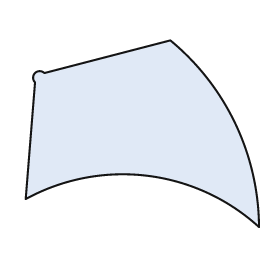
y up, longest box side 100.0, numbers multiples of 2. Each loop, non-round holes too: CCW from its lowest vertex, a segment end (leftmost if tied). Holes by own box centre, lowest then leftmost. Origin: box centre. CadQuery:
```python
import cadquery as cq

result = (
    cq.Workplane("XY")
    .moveTo(50.0, -40.0)
    .threePointArc((40.0, 4.0), (12.0, 40.0))
    .lineTo(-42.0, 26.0)
    .threePointArc((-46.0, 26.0), (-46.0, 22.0))
    .lineTo(-50.0, -28.0)
    .threePointArc((2.0, -18.0), (50.0, -40.0))
    .close()
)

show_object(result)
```